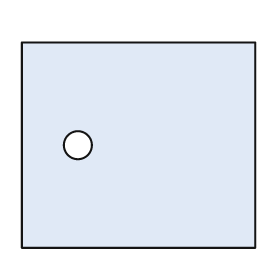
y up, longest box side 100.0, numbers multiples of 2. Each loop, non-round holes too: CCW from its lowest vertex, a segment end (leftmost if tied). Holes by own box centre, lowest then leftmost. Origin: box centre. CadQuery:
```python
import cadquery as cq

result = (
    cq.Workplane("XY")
    .moveTo(-50.0, -44.0)
    .lineTo(50.0, -44.0)
    .lineTo(50.0, 44.0)
    .lineTo(-50.0, 44.0)
    .close()
    .moveTo(-26.0, 0.0)
    .circle(6.0)
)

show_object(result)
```